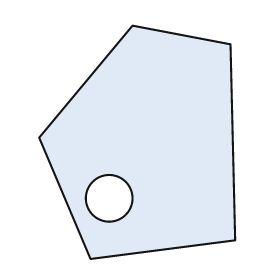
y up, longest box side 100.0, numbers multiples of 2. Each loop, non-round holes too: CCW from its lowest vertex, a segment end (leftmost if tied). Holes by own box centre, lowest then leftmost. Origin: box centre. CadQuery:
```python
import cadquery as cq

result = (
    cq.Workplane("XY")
    .moveTo(-20.0, -50.0)
    .lineTo(42.0, -42.0)
    .lineTo(40.0, 42.0)
    .lineTo(-2.0, 50.0)
    .lineTo(-42.0, 2.0)
    .close()
    .moveTo(-12.0, -24.0)
    .circle(10.0)
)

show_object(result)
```